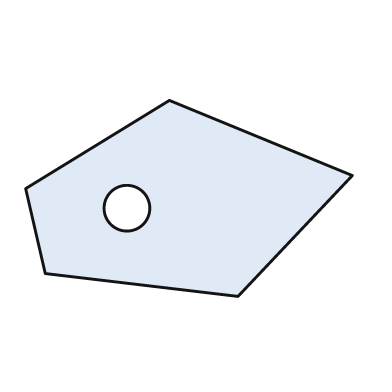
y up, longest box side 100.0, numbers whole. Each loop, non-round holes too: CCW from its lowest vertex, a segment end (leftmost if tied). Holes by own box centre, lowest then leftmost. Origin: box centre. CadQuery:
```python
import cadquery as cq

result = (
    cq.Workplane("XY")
    .moveTo(15.0, -30.0)
    .lineTo(50.0, 7.0)
    .lineTo(-6.0, 30.0)
    .lineTo(-50.0, 3.0)
    .lineTo(-44.0, -23.0)
    .close()
    .moveTo(-19.0, -3.0)
    .circle(7.0)
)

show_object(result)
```